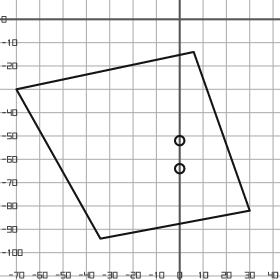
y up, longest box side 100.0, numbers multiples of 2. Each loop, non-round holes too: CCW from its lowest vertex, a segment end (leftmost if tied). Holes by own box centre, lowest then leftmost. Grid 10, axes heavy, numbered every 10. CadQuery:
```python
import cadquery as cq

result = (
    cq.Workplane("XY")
    .moveTo(-34.0, -94.0)
    .lineTo(30.0, -82.0)
    .lineTo(6.0, -14.0)
    .lineTo(-70.0, -30.0)
    .close()
    .moveTo(0.0, -64.0)
    .circle(2.0)
    .moveTo(0.0, -52.0)
    .circle(2.0)
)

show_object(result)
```